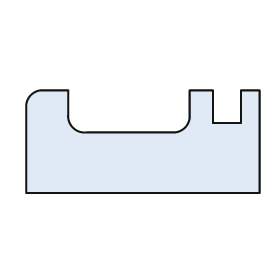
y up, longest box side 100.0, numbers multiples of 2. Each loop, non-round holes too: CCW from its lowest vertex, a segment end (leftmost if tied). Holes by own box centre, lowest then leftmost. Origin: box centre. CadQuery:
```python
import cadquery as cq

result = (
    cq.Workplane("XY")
    .moveTo(-50.0, -22.0)
    .lineTo(50.0, -22.0)
    .lineTo(50.0, 22.0)
    .lineTo(42.0, 22.0)
    .lineTo(42.0, 8.0)
    .lineTo(30.0, 8.0)
    .lineTo(30.0, 22.0)
    .lineTo(20.0, 22.0)
    .lineTo(20.0, 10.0)
    .threePointArc((18.0, 6.0), (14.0, 4.0))
    .lineTo(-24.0, 4.0)
    .threePointArc((-30.0, 6.0), (-32.0, 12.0))
    .lineTo(-32.0, 22.0)
    .lineTo(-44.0, 22.0)
    .threePointArc((-48.0, 20.0), (-50.0, 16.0))
    .close()
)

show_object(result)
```